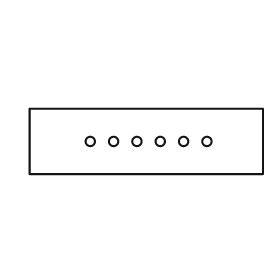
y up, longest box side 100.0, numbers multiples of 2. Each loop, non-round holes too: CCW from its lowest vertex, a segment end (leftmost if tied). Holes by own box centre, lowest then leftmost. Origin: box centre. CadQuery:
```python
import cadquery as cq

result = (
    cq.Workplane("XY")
    .moveTo(-50.0, -14.0)
    .lineTo(50.0, -14.0)
    .lineTo(50.0, 14.0)
    .lineTo(-50.0, 14.0)
    .close()
    .moveTo(-24.0, 0.0)
    .circle(2.0)
    .moveTo(-14.0, 0.0)
    .circle(2.0)
    .moveTo(-4.0, 0.0)
    .circle(2.0)
    .moveTo(6.0, 0.0)
    .circle(2.0)
    .moveTo(16.0, 0.0)
    .circle(2.0)
    .moveTo(26.0, 0.0)
    .circle(2.0)
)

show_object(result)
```